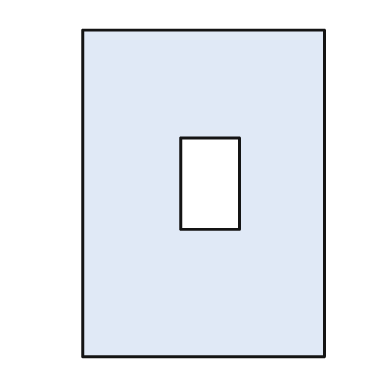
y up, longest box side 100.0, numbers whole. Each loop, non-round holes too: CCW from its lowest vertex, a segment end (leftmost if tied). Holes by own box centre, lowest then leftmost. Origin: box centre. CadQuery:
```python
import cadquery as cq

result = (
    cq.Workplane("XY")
    .moveTo(-37.0, -50.0)
    .lineTo(37.0, -50.0)
    .lineTo(37.0, 50.0)
    .lineTo(-37.0, 50.0)
    .close()
    .moveTo(-7.0, -11.0)
    .lineTo(11.0, -11.0)
    .lineTo(11.0, 17.0)
    .lineTo(-7.0, 17.0)
    .close()
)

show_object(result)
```